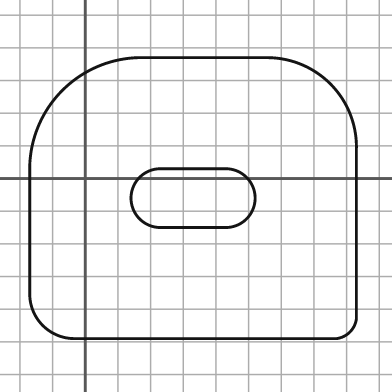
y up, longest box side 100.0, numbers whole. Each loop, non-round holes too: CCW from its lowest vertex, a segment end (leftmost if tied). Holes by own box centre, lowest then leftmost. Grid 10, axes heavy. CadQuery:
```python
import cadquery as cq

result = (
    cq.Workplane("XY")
    .moveTo(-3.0, -49.0)
    .lineTo(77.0, -49.0)
    .threePointArc((81.0, -47.0), (83.0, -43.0))
    .lineTo(83.0, 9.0)
    .threePointArc((75.0, 29.0), (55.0, 37.0))
    .lineTo(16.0, 37.0)
    .threePointArc((-7.0, 27.0), (-17.0, 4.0))
    .lineTo(-17.0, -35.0)
    .threePointArc((-13.0, -45.0), (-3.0, -49.0))
    .close()
    .moveTo(23.0, -15.0)
    .lineTo(43.0, -15.0)
    .threePointArc((52.0, -6.0), (43.0, 3.0))
    .lineTo(23.0, 3.0)
    .threePointArc((14.0, -6.0), (23.0, -15.0))
    .close()
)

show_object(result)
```